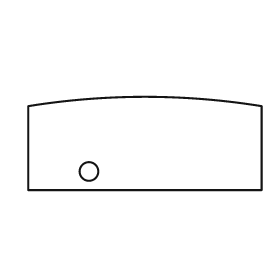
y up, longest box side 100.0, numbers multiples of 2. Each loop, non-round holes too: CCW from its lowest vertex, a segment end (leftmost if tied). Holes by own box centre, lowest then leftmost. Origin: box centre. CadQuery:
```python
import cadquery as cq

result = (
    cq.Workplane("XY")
    .moveTo(-50.0, -20.0)
    .lineTo(50.0, -20.0)
    .lineTo(50.0, 16.0)
    .threePointArc((0.0, 20.0), (-50.0, 16.0))
    .close()
    .moveTo(-24.0, -12.0)
    .circle(4.0)
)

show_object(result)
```